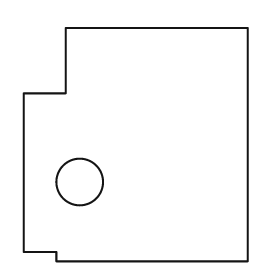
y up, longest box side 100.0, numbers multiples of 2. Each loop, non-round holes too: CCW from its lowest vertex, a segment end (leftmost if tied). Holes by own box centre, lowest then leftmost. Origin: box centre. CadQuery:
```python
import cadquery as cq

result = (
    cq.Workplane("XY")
    .moveTo(-34.0, -50.0)
    .lineTo(48.0, -50.0)
    .lineTo(48.0, 50.0)
    .lineTo(-30.0, 50.0)
    .lineTo(-30.0, 22.0)
    .lineTo(-48.0, 22.0)
    .lineTo(-48.0, -46.0)
    .lineTo(-34.0, -46.0)
    .close()
    .moveTo(-24.0, -16.0)
    .circle(10.0)
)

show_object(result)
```